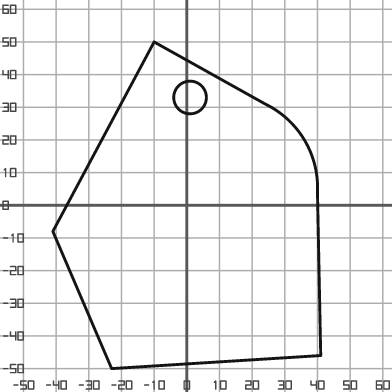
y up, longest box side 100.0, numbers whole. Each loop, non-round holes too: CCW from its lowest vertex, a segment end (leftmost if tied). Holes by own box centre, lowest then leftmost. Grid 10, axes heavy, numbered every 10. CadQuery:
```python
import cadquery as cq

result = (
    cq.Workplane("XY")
    .moveTo(-23.0, -50.0)
    .lineTo(41.0, -46.0)
    .lineTo(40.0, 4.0)
    .threePointArc((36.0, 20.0), (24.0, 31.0))
    .lineTo(-10.0, 50.0)
    .lineTo(-41.0, -8.0)
    .close()
    .moveTo(1.0, 33.0)
    .circle(5.0)
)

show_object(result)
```